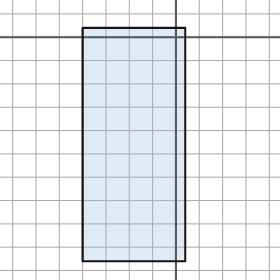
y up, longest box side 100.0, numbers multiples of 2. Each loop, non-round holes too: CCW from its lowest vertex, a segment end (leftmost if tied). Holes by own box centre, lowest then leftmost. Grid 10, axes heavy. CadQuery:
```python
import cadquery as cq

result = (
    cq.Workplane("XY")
    .moveTo(-40.0, -96.0)
    .lineTo(4.0, -96.0)
    .lineTo(4.0, 4.0)
    .lineTo(-40.0, 4.0)
    .close()
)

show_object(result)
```